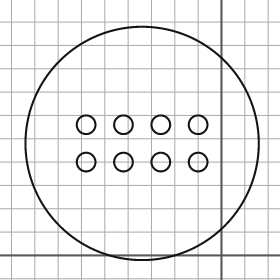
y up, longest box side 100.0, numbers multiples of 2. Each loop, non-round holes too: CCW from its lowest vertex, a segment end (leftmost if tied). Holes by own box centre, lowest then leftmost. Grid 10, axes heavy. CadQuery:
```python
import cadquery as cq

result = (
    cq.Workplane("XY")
    .moveTo(-34.0, 48.0)
    .circle(50.0)
    .moveTo(-58.0, 40.0)
    .circle(4.0)
    .moveTo(-42.0, 40.0)
    .circle(4.0)
    .moveTo(-26.0, 40.0)
    .circle(4.0)
    .moveTo(-10.0, 40.0)
    .circle(4.0)
    .moveTo(-58.0, 56.0)
    .circle(4.0)
    .moveTo(-42.0, 56.0)
    .circle(4.0)
    .moveTo(-26.0, 56.0)
    .circle(4.0)
    .moveTo(-10.0, 56.0)
    .circle(4.0)
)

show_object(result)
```